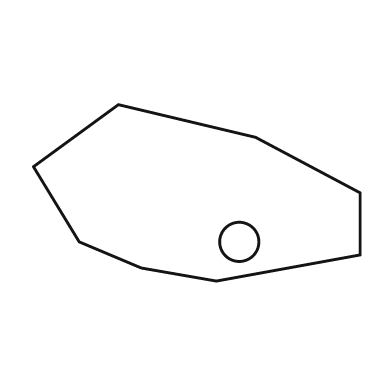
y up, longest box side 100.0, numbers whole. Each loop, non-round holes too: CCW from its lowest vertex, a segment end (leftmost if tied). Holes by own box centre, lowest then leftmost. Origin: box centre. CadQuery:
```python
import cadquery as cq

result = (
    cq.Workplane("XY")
    .moveTo(6.0, -27.0)
    .lineTo(50.0, -19.0)
    .lineTo(50.0, 0.0)
    .lineTo(18.0, 17.0)
    .lineTo(-24.0, 27.0)
    .lineTo(-50.0, 8.0)
    .lineTo(-36.0, -15.0)
    .lineTo(-17.0, -23.0)
    .close()
    .moveTo(13.0, -15.0)
    .circle(6.0)
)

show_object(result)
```